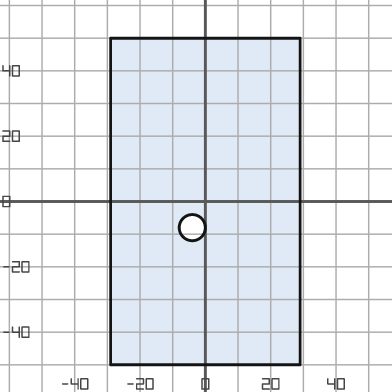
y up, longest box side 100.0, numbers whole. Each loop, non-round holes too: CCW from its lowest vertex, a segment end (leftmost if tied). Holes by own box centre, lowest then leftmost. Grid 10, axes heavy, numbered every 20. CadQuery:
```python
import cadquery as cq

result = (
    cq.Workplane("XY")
    .moveTo(-29.0, -50.0)
    .lineTo(29.0, -50.0)
    .lineTo(29.0, 50.0)
    .lineTo(-29.0, 50.0)
    .close()
    .moveTo(-4.0, -8.0)
    .circle(4.0)
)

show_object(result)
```